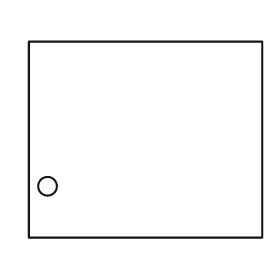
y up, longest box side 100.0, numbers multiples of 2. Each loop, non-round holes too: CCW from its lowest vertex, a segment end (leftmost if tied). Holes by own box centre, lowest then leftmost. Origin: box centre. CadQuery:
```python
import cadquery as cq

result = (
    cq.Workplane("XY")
    .moveTo(-50.0, -42.0)
    .lineTo(50.0, -42.0)
    .lineTo(50.0, 42.0)
    .lineTo(-50.0, 42.0)
    .close()
    .moveTo(-42.0, -20.0)
    .circle(4.0)
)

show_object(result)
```